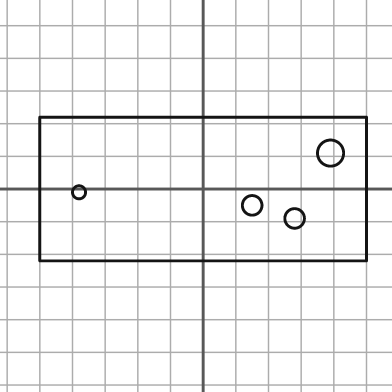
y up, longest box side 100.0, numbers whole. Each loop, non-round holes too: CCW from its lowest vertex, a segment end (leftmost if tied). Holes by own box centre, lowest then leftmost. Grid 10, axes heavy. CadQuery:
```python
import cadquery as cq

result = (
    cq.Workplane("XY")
    .moveTo(-50.0, -22.0)
    .lineTo(50.0, -22.0)
    .lineTo(50.0, 22.0)
    .lineTo(-50.0, 22.0)
    .close()
    .moveTo(28.0, -9.0)
    .circle(3.0)
    .moveTo(15.0, -5.0)
    .circle(3.0)
    .moveTo(-38.0, -1.0)
    .circle(2.0)
    .moveTo(39.0, 11.0)
    .circle(4.0)
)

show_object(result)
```